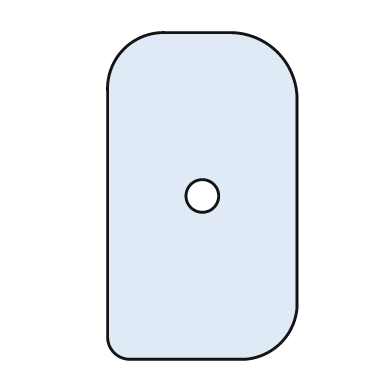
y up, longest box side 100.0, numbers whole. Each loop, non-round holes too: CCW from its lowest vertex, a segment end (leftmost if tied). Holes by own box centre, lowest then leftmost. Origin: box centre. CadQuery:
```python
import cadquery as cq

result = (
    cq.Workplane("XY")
    .moveTo(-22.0, -50.0)
    .lineTo(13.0, -50.0)
    .threePointArc((24.0, -45.0), (29.0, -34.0))
    .lineTo(29.0, 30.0)
    .threePointArc((23.0, 44.0), (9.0, 50.0))
    .lineTo(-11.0, 50.0)
    .threePointArc((-24.0, 45.0), (-29.0, 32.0))
    .lineTo(-29.0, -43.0)
    .threePointArc((-27.0, -48.0), (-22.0, -50.0))
    .close()
    .moveTo(0.0, 0.0)
    .circle(5.0)
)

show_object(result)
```